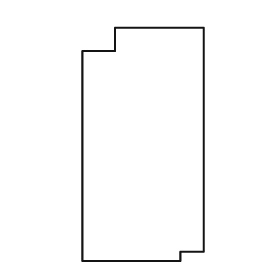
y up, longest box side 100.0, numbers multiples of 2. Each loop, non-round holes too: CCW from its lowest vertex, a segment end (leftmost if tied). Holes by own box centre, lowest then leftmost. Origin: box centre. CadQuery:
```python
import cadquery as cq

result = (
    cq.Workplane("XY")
    .moveTo(-26.0, -50.0)
    .lineTo(16.0, -50.0)
    .lineTo(16.0, -46.0)
    .lineTo(26.0, -46.0)
    .lineTo(26.0, 50.0)
    .lineTo(-12.0, 50.0)
    .lineTo(-12.0, 40.0)
    .lineTo(-26.0, 40.0)
    .close()
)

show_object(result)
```